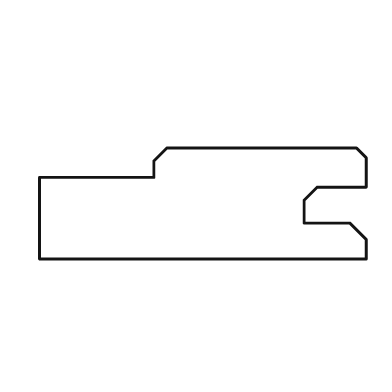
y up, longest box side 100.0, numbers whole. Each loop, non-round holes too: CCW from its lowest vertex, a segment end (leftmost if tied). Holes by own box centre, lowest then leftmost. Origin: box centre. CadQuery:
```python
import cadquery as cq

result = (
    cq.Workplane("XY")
    .moveTo(-50.0, -17.0)
    .lineTo(50.0, -17.0)
    .lineTo(50.0, -11.0)
    .lineTo(45.0, -6.0)
    .lineTo(31.0, -6.0)
    .lineTo(31.0, 1.0)
    .lineTo(35.0, 5.0)
    .lineTo(50.0, 5.0)
    .lineTo(50.0, 14.0)
    .lineTo(47.0, 17.0)
    .lineTo(-11.0, 17.0)
    .lineTo(-15.0, 13.0)
    .lineTo(-15.0, 8.0)
    .lineTo(-50.0, 8.0)
    .close()
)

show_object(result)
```